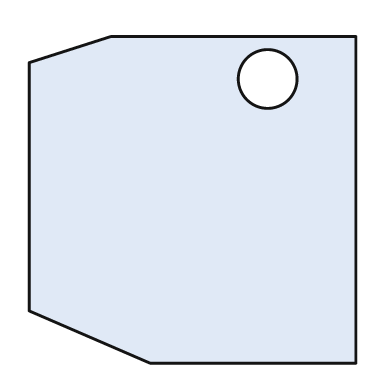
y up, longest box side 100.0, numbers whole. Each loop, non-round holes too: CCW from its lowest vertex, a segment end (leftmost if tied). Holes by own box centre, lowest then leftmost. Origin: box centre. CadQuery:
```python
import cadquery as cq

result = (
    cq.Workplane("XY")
    .moveTo(-13.0, -50.0)
    .lineTo(50.0, -50.0)
    .lineTo(50.0, 50.0)
    .lineTo(-25.0, 50.0)
    .lineTo(-50.0, 42.0)
    .lineTo(-50.0, -34.0)
    .close()
    .moveTo(23.0, 37.0)
    .circle(9.0)
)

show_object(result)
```